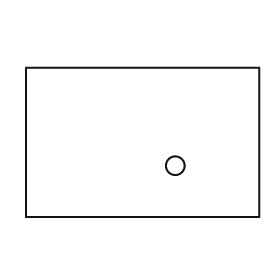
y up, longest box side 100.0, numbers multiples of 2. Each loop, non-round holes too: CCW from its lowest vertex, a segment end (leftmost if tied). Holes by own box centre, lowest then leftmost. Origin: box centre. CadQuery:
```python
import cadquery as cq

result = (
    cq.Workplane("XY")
    .moveTo(-50.0, -32.0)
    .lineTo(50.0, -32.0)
    .lineTo(50.0, 32.0)
    .lineTo(-50.0, 32.0)
    .close()
    .moveTo(14.0, -10.0)
    .circle(4.0)
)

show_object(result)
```